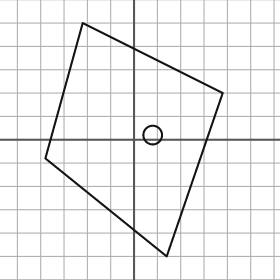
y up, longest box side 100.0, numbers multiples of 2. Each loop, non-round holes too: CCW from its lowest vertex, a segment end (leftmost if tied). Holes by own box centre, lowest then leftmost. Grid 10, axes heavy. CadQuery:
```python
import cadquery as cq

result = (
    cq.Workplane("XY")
    .moveTo(14.0, -50.0)
    .lineTo(38.0, 20.0)
    .lineTo(-22.0, 50.0)
    .lineTo(-38.0, -8.0)
    .close()
    .moveTo(8.0, 2.0)
    .circle(4.0)
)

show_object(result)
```